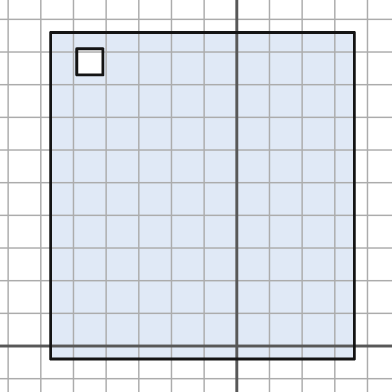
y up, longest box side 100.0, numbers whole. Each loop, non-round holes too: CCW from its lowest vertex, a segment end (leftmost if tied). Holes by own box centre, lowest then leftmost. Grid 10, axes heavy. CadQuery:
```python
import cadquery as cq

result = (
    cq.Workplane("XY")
    .moveTo(-57.0, -4.0)
    .lineTo(36.0, -4.0)
    .lineTo(36.0, 96.0)
    .lineTo(-57.0, 96.0)
    .close()
    .moveTo(-49.0, 83.0)
    .lineTo(-41.0, 83.0)
    .lineTo(-41.0, 91.0)
    .lineTo(-49.0, 91.0)
    .close()
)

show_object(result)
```